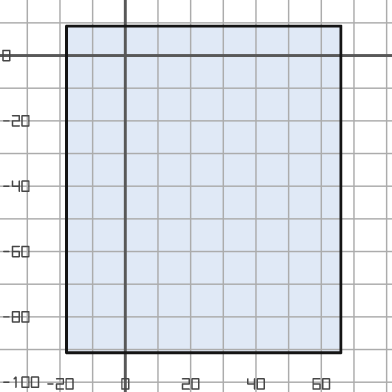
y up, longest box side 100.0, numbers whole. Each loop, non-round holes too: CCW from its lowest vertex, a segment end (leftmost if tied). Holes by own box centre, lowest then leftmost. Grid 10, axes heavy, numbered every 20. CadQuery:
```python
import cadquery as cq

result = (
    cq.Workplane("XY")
    .moveTo(-18.0, -91.0)
    .lineTo(66.0, -91.0)
    .lineTo(66.0, 9.0)
    .lineTo(-18.0, 9.0)
    .close()
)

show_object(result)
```